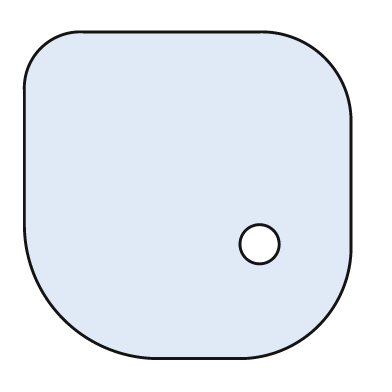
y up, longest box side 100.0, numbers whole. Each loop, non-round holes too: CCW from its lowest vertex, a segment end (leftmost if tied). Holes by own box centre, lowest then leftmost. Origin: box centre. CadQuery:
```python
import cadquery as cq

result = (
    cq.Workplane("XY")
    .moveTo(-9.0, -50.0)
    .lineTo(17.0, -50.0)
    .threePointArc((40.0, -40.0), (50.0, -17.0))
    .lineTo(50.0, 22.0)
    .threePointArc((42.0, 42.0), (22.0, 50.0))
    .lineTo(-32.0, 50.0)
    .threePointArc((-45.0, 45.0), (-50.0, 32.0))
    .lineTo(-50.0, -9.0)
    .threePointArc((-38.0, -38.0), (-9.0, -50.0))
    .close()
    .moveTo(22.0, -15.0)
    .circle(6.0)
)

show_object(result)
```